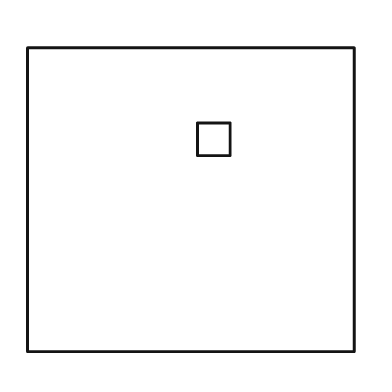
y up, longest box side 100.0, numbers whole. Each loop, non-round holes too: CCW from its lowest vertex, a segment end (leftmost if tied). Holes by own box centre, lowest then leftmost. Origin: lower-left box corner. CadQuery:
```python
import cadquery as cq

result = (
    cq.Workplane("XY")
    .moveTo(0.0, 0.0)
    .lineTo(100.0, 0.0)
    .lineTo(100.0, 93.0)
    .lineTo(0.0, 93.0)
    .close()
    .moveTo(52.0, 60.0)
    .lineTo(62.0, 60.0)
    .lineTo(62.0, 70.0)
    .lineTo(52.0, 70.0)
    .close()
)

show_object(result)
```